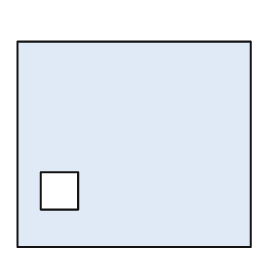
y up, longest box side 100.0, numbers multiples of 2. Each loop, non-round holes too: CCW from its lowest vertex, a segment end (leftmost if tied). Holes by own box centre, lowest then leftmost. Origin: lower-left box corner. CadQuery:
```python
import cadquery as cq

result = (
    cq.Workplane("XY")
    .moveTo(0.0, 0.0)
    .lineTo(100.0, 0.0)
    .lineTo(100.0, 88.0)
    .lineTo(0.0, 88.0)
    .close()
    .moveTo(10.0, 16.0)
    .lineTo(26.0, 16.0)
    .lineTo(26.0, 32.0)
    .lineTo(10.0, 32.0)
    .close()
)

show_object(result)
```